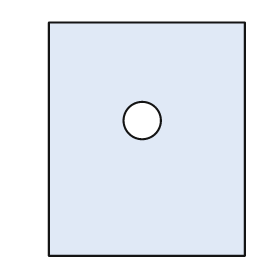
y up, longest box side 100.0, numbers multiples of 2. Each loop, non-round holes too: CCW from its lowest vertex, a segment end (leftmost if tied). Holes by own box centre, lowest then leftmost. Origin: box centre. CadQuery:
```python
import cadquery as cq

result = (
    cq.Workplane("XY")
    .moveTo(-42.0, -50.0)
    .lineTo(42.0, -50.0)
    .lineTo(42.0, 50.0)
    .lineTo(-42.0, 50.0)
    .close()
    .moveTo(-2.0, 8.0)
    .circle(8.0)
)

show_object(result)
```